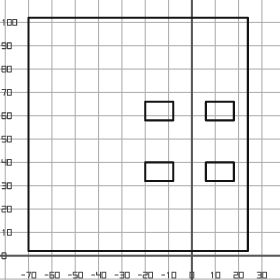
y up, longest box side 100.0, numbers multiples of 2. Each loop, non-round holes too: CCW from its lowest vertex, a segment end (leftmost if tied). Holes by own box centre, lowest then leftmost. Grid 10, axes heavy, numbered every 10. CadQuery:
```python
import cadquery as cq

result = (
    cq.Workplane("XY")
    .moveTo(-70.0, 2.0)
    .lineTo(24.0, 2.0)
    .lineTo(24.0, 102.0)
    .lineTo(-70.0, 102.0)
    .close()
    .moveTo(-20.0, 32.0)
    .lineTo(-8.0, 32.0)
    .lineTo(-8.0, 40.0)
    .lineTo(-20.0, 40.0)
    .close()
    .moveTo(6.0, 32.0)
    .lineTo(18.0, 32.0)
    .lineTo(18.0, 40.0)
    .lineTo(6.0, 40.0)
    .close()
    .moveTo(-20.0, 58.0)
    .lineTo(-8.0, 58.0)
    .lineTo(-8.0, 66.0)
    .lineTo(-20.0, 66.0)
    .close()
    .moveTo(6.0, 58.0)
    .lineTo(18.0, 58.0)
    .lineTo(18.0, 66.0)
    .lineTo(6.0, 66.0)
    .close()
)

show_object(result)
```